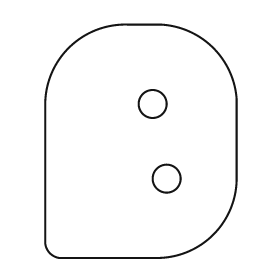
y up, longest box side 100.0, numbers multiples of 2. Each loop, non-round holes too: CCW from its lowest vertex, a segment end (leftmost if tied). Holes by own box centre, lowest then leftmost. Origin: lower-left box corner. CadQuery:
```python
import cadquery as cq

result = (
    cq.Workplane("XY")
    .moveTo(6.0, 0.0)
    .lineTo(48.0, 0.0)
    .threePointArc((72.0, 10.0), (82.0, 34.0))
    .lineTo(82.0, 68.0)
    .threePointArc((72.0, 90.0), (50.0, 100.0))
    .lineTo(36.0, 100.0)
    .threePointArc((10.0, 90.0), (0.0, 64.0))
    .lineTo(0.0, 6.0)
    .threePointArc((2.0, 2.0), (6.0, 0.0))
    .close()
    .moveTo(52.0, 34.0)
    .circle(6.0)
    .moveTo(46.0, 66.0)
    .circle(6.0)
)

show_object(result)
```